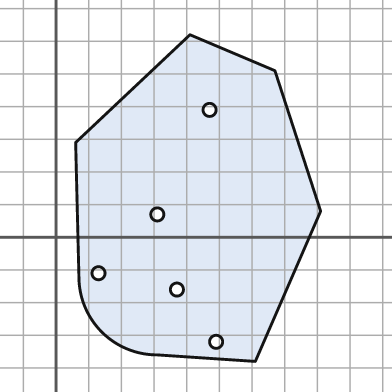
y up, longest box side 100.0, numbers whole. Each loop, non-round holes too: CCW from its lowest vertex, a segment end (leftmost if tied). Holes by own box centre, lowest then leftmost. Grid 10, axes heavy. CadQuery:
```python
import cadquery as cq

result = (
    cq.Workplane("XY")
    .moveTo(61.0, -38.0)
    .lineTo(81.0, 8.0)
    .lineTo(67.0, 51.0)
    .lineTo(41.0, 62.0)
    .lineTo(6.0, 29.0)
    .lineTo(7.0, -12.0)
    .threePointArc((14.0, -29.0), (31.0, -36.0))
    .close()
    .moveTo(49.0, -32.0)
    .circle(2.0)
    .moveTo(37.0, -16.0)
    .circle(2.0)
    .moveTo(13.0, -11.0)
    .circle(2.0)
    .moveTo(31.0, 7.0)
    .circle(2.0)
    .moveTo(47.0, 39.0)
    .circle(2.0)
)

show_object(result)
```